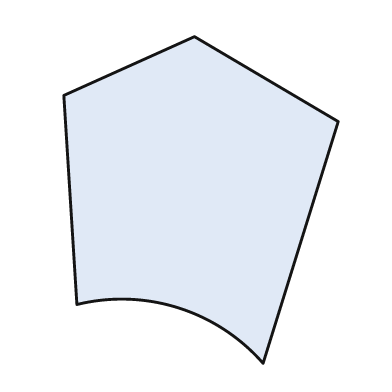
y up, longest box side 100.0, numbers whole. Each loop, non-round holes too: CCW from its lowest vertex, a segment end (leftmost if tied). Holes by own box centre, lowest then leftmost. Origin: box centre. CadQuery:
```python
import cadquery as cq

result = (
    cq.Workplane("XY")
    .moveTo(19.0, -50.0)
    .lineTo(42.0, 24.0)
    .lineTo(-2.0, 50.0)
    .lineTo(-42.0, 32.0)
    .lineTo(-38.0, -32.0)
    .threePointArc((-7.0, -33.0), (19.0, -50.0))
    .close()
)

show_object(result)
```